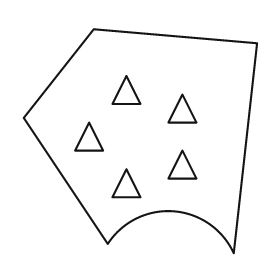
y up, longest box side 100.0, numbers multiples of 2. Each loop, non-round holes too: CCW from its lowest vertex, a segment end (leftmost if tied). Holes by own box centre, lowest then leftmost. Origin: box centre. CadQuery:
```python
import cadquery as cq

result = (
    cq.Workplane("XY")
    .moveTo(40.0, -48.0)
    .lineTo(50.0, 42.0)
    .lineTo(-20.0, 48.0)
    .lineTo(-50.0, 10.0)
    .lineTo(-14.0, -44.0)
    .threePointArc((14.0, -30.0), (40.0, -48.0))
    .close()
    .moveTo(-12.0, -24.0)
    .lineTo(0.0, -24.0)
    .lineTo(-6.0, -12.0)
    .close()
    .moveTo(12.0, -16.0)
    .lineTo(24.0, -16.0)
    .lineTo(18.0, -4.0)
    .close()
    .moveTo(-28.0, -4.0)
    .lineTo(-16.0, -4.0)
    .lineTo(-22.0, 8.0)
    .close()
    .moveTo(12.0, 8.0)
    .lineTo(24.0, 8.0)
    .lineTo(18.0, 20.0)
    .close()
    .moveTo(-12.0, 16.0)
    .lineTo(0.0, 16.0)
    .lineTo(-6.0, 28.0)
    .close()
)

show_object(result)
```